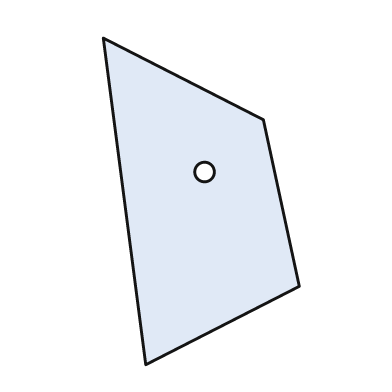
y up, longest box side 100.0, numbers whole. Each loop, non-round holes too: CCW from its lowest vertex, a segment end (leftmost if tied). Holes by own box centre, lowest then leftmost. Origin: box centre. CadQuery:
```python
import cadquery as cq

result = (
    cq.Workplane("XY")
    .moveTo(-17.0, -50.0)
    .lineTo(30.0, -26.0)
    .lineTo(19.0, 25.0)
    .lineTo(-30.0, 50.0)
    .close()
    .moveTo(1.0, 9.0)
    .circle(3.0)
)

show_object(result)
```